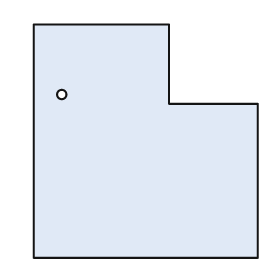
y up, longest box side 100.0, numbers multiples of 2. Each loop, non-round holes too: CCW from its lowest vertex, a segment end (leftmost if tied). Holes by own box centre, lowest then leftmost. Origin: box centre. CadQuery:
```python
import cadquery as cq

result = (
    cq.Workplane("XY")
    .moveTo(-48.0, -50.0)
    .lineTo(48.0, -50.0)
    .lineTo(48.0, 16.0)
    .lineTo(10.0, 16.0)
    .lineTo(10.0, 50.0)
    .lineTo(-48.0, 50.0)
    .close()
    .moveTo(-36.0, 20.0)
    .circle(2.0)
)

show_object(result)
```